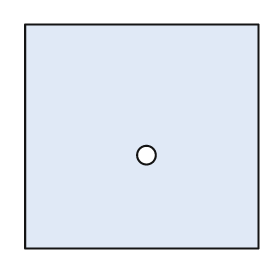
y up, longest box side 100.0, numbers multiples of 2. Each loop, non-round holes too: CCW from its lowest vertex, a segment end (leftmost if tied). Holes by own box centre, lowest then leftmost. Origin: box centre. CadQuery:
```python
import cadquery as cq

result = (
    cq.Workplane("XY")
    .moveTo(-50.0, -48.0)
    .lineTo(50.0, -48.0)
    .lineTo(50.0, 48.0)
    .lineTo(-50.0, 48.0)
    .close()
    .moveTo(2.0, -8.0)
    .circle(4.0)
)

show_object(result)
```